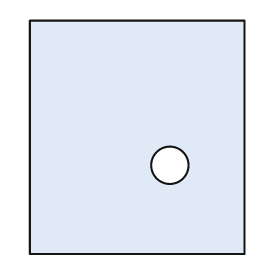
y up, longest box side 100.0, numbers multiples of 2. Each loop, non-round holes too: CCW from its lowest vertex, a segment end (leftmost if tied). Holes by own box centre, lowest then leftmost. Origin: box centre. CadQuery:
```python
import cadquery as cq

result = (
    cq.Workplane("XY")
    .moveTo(-46.0, -50.0)
    .lineTo(46.0, -50.0)
    .lineTo(46.0, 50.0)
    .lineTo(-46.0, 50.0)
    .close()
    .moveTo(14.0, -12.0)
    .circle(8.0)
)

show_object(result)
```